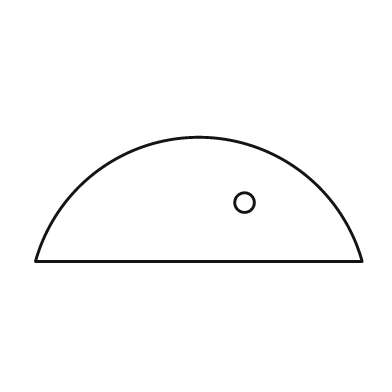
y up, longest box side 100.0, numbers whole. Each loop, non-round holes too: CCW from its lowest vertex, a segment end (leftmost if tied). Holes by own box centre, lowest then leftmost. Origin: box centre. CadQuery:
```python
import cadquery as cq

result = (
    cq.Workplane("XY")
    .moveTo(-50.0, -19.0)
    .lineTo(50.0, -19.0)
    .threePointArc((0.0, 19.0), (-50.0, -19.0))
    .close()
    .moveTo(14.0, -1.0)
    .circle(3.0)
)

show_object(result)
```